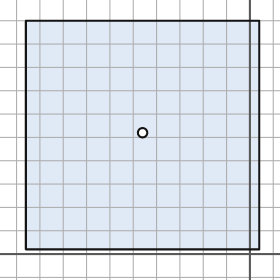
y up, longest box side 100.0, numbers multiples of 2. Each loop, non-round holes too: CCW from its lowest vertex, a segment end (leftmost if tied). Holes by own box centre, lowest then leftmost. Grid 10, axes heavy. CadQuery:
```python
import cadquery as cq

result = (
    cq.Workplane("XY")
    .moveTo(-96.0, 2.0)
    .lineTo(4.0, 2.0)
    .lineTo(4.0, 100.0)
    .lineTo(-96.0, 100.0)
    .close()
    .moveTo(-46.0, 52.0)
    .circle(2.0)
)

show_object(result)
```